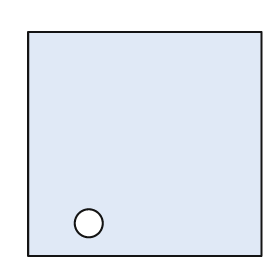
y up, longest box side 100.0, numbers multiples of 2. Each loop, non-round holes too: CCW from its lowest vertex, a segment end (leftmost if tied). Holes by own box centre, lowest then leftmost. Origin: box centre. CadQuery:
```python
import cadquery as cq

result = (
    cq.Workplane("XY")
    .moveTo(-50.0, -48.0)
    .lineTo(50.0, -48.0)
    .lineTo(50.0, 48.0)
    .lineTo(-50.0, 48.0)
    .close()
    .moveTo(-24.0, -34.0)
    .circle(6.0)
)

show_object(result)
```